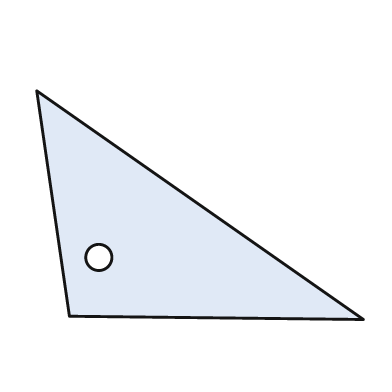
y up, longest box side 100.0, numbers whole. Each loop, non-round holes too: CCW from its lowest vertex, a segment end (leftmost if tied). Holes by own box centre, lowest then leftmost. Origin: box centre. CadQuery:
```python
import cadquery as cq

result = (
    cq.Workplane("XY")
    .moveTo(50.0, -35.0)
    .lineTo(-50.0, 35.0)
    .lineTo(-40.0, -34.0)
    .close()
    .moveTo(-31.0, -16.0)
    .circle(4.0)
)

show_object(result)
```